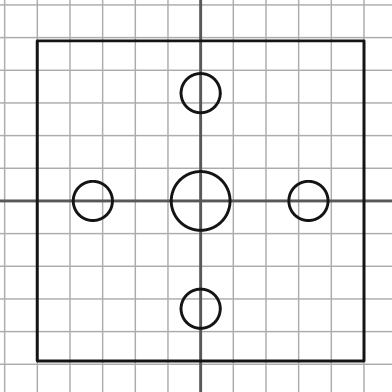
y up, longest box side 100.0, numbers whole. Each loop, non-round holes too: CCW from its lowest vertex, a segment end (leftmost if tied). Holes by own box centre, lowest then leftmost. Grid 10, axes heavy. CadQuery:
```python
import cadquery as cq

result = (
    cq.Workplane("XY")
    .moveTo(-50.0, -49.0)
    .lineTo(50.0, -49.0)
    .lineTo(50.0, 49.0)
    .lineTo(-50.0, 49.0)
    .close()
    .moveTo(0.0, -33.0)
    .circle(6.0)
    .moveTo(-33.0, 0.0)
    .circle(6.0)
    .moveTo(0.0, 0.0)
    .circle(9.0)
    .moveTo(33.0, 0.0)
    .circle(6.0)
    .moveTo(0.0, 33.0)
    .circle(6.0)
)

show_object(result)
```